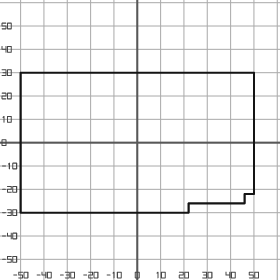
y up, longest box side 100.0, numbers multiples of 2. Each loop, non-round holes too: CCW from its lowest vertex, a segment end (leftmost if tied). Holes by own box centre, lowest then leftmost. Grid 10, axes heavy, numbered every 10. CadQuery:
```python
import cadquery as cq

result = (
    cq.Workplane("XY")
    .moveTo(-50.0, -30.0)
    .lineTo(22.0, -30.0)
    .lineTo(22.0, -26.0)
    .lineTo(46.0, -26.0)
    .lineTo(46.0, -22.0)
    .lineTo(50.0, -22.0)
    .lineTo(50.0, 30.0)
    .lineTo(-50.0, 30.0)
    .close()
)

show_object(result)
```